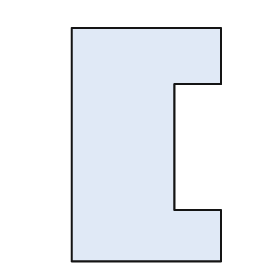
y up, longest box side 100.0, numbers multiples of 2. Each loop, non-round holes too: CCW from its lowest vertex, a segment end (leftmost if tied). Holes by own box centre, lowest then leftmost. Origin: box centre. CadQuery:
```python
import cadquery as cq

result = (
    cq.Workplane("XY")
    .moveTo(-32.0, -50.0)
    .lineTo(32.0, -50.0)
    .lineTo(32.0, -28.0)
    .lineTo(12.0, -28.0)
    .lineTo(12.0, 26.0)
    .lineTo(32.0, 26.0)
    .lineTo(32.0, 50.0)
    .lineTo(-32.0, 50.0)
    .close()
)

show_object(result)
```